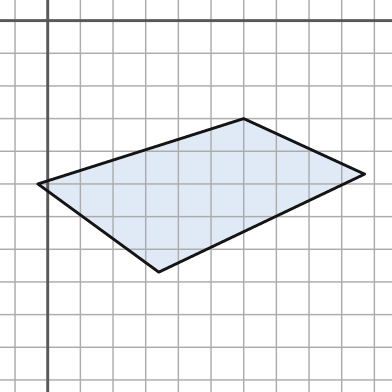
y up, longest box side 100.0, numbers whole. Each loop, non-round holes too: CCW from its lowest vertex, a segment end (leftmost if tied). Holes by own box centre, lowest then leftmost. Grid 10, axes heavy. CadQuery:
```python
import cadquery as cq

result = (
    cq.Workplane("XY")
    .moveTo(34.0, -77.0)
    .lineTo(97.0, -47.0)
    .lineTo(60.0, -30.0)
    .lineTo(-3.0, -50.0)
    .close()
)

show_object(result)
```